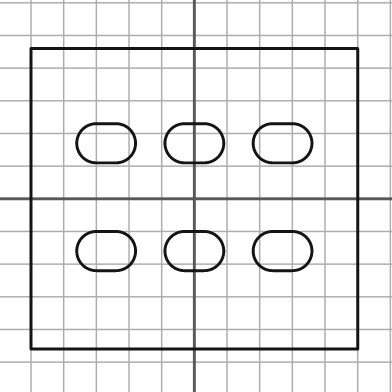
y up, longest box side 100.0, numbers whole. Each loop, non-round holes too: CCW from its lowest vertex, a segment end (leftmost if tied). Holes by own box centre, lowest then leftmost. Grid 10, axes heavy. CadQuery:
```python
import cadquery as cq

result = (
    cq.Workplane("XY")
    .moveTo(-50.0, -46.0)
    .lineTo(50.0, -46.0)
    .lineTo(50.0, 46.0)
    .lineTo(-50.0, 46.0)
    .close()
    .moveTo(-30.0, -22.0)
    .lineTo(-24.0, -22.0)
    .threePointArc((-18.0, -16.0), (-24.0, -10.0))
    .lineTo(-30.0, -10.0)
    .threePointArc((-36.0, -16.0), (-30.0, -22.0))
    .close()
    .moveTo(-3.0, -22.0)
    .lineTo(3.0, -22.0)
    .threePointArc((9.0, -16.0), (3.0, -10.0))
    .lineTo(-3.0, -10.0)
    .threePointArc((-9.0, -16.0), (-3.0, -22.0))
    .close()
    .moveTo(24.0, -22.0)
    .lineTo(30.0, -22.0)
    .threePointArc((36.0, -16.0), (30.0, -10.0))
    .lineTo(24.0, -10.0)
    .threePointArc((18.0, -16.0), (24.0, -22.0))
    .close()
    .moveTo(-30.0, 11.0)
    .lineTo(-24.0, 11.0)
    .threePointArc((-18.0, 17.0), (-24.0, 23.0))
    .lineTo(-30.0, 23.0)
    .threePointArc((-36.0, 17.0), (-30.0, 11.0))
    .close()
    .moveTo(-3.0, 11.0)
    .lineTo(3.0, 11.0)
    .threePointArc((9.0, 17.0), (3.0, 23.0))
    .lineTo(-3.0, 23.0)
    .threePointArc((-9.0, 17.0), (-3.0, 11.0))
    .close()
    .moveTo(24.0, 11.0)
    .lineTo(30.0, 11.0)
    .threePointArc((36.0, 17.0), (30.0, 23.0))
    .lineTo(24.0, 23.0)
    .threePointArc((18.0, 17.0), (24.0, 11.0))
    .close()
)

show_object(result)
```